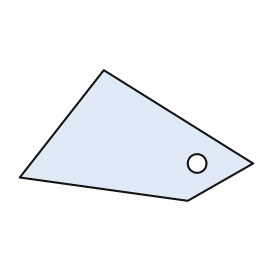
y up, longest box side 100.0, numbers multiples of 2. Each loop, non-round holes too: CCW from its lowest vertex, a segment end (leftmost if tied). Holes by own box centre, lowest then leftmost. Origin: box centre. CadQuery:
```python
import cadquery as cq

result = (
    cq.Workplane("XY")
    .moveTo(22.0, -28.0)
    .lineTo(50.0, -12.0)
    .lineTo(-14.0, 28.0)
    .lineTo(-50.0, -18.0)
    .close()
    .moveTo(26.0, -12.0)
    .circle(4.0)
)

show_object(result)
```